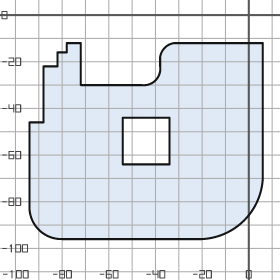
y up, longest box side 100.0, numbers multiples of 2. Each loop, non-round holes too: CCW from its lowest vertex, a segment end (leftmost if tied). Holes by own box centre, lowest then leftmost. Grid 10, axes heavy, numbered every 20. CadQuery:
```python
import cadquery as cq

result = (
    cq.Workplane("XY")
    .moveTo(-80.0, -96.0)
    .lineTo(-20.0, -96.0)
    .threePointArc((-2.0, -88.0), (6.0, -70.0))
    .lineTo(6.0, -12.0)
    .lineTo(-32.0, -12.0)
    .threePointArc((-36.0, -14.0), (-38.0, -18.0))
    .lineTo(-38.0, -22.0)
    .threePointArc((-40.0, -28.0), (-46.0, -30.0))
    .lineTo(-72.0, -30.0)
    .lineTo(-72.0, -12.0)
    .lineTo(-78.0, -12.0)
    .lineTo(-78.0, -16.0)
    .lineTo(-82.0, -16.0)
    .lineTo(-82.0, -22.0)
    .lineTo(-88.0, -22.0)
    .lineTo(-88.0, -46.0)
    .lineTo(-94.0, -46.0)
    .lineTo(-94.0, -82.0)
    .threePointArc((-90.0, -92.0), (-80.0, -96.0))
    .close()
    .moveTo(-54.0, -64.0)
    .lineTo(-34.0, -64.0)
    .lineTo(-34.0, -44.0)
    .lineTo(-54.0, -44.0)
    .close()
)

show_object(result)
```